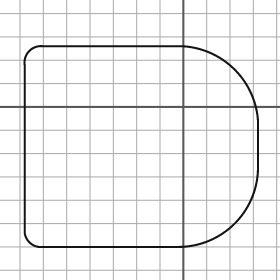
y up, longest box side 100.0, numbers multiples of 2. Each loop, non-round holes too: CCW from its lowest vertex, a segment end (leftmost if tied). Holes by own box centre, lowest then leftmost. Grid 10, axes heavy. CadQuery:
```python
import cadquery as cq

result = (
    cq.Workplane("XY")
    .moveTo(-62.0, -60.0)
    .lineTo(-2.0, -60.0)
    .threePointArc((22.0, -50.0), (32.0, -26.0))
    .lineTo(32.0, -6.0)
    .threePointArc((22.0, 16.0), (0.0, 26.0))
    .lineTo(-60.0, 26.0)
    .threePointArc((-66.0, 24.0), (-68.0, 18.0))
    .lineTo(-68.0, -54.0)
    .threePointArc((-66.0, -58.0), (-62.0, -60.0))
    .close()
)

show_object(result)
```